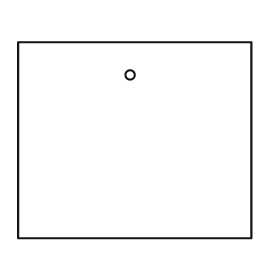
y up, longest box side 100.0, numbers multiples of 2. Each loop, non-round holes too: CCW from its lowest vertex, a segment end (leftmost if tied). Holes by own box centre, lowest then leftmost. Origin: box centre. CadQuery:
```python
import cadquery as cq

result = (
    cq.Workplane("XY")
    .moveTo(-50.0, -42.0)
    .lineTo(50.0, -42.0)
    .lineTo(50.0, 42.0)
    .lineTo(-50.0, 42.0)
    .close()
    .moveTo(-2.0, 28.0)
    .circle(2.0)
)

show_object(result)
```